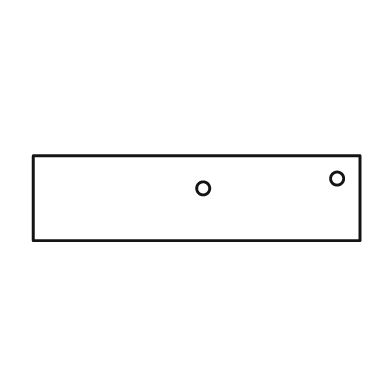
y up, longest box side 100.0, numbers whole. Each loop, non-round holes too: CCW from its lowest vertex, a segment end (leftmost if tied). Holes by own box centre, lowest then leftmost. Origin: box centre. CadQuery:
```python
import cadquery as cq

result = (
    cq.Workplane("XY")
    .moveTo(-50.0, -13.0)
    .lineTo(50.0, -13.0)
    .lineTo(50.0, 13.0)
    .lineTo(-50.0, 13.0)
    .close()
    .moveTo(2.0, 3.0)
    .circle(2.0)
    .moveTo(43.0, 6.0)
    .circle(2.0)
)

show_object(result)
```